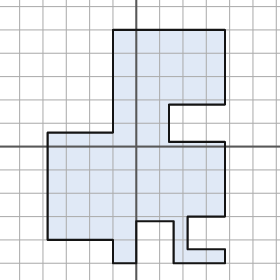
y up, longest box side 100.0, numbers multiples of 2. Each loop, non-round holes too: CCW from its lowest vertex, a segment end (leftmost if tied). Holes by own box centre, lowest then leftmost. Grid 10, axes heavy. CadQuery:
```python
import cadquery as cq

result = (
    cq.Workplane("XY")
    .moveTo(-10.0, -50.0)
    .lineTo(0.0, -50.0)
    .lineTo(0.0, -32.0)
    .lineTo(16.0, -32.0)
    .lineTo(16.0, -50.0)
    .lineTo(38.0, -50.0)
    .lineTo(38.0, -44.0)
    .lineTo(22.0, -44.0)
    .lineTo(22.0, -30.0)
    .lineTo(38.0, -30.0)
    .lineTo(38.0, 2.0)
    .lineTo(14.0, 2.0)
    .lineTo(14.0, 18.0)
    .lineTo(38.0, 18.0)
    .lineTo(38.0, 50.0)
    .lineTo(-10.0, 50.0)
    .lineTo(-10.0, 6.0)
    .lineTo(-38.0, 6.0)
    .lineTo(-38.0, -40.0)
    .lineTo(-10.0, -40.0)
    .close()
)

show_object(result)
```